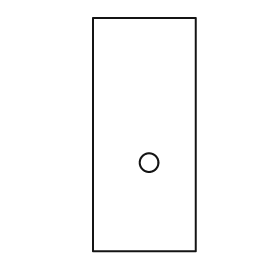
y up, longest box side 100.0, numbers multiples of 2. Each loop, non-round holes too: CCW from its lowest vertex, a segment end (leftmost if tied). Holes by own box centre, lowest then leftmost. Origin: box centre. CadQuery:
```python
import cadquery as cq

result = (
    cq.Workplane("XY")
    .moveTo(-22.0, -50.0)
    .lineTo(22.0, -50.0)
    .lineTo(22.0, 50.0)
    .lineTo(-22.0, 50.0)
    .close()
    .moveTo(2.0, -12.0)
    .circle(4.0)
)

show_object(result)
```